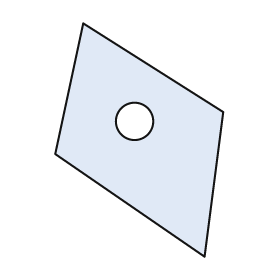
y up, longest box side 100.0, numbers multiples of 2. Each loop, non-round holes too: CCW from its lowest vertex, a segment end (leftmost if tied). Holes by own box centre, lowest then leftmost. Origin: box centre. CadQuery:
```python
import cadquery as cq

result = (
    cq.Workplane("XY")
    .moveTo(28.0, -50.0)
    .lineTo(36.0, 12.0)
    .lineTo(-24.0, 50.0)
    .lineTo(-36.0, -6.0)
    .close()
    .moveTo(-2.0, 8.0)
    .circle(8.0)
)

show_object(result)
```